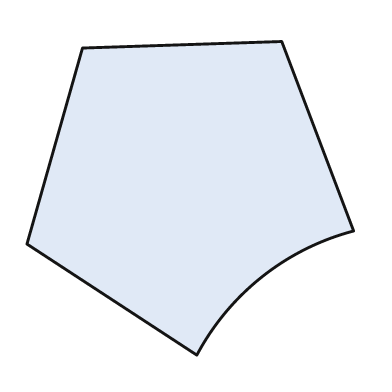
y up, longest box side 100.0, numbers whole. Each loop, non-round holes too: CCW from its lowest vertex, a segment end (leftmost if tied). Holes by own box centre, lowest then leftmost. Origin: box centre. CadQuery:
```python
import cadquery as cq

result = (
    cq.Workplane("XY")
    .moveTo(2.0, -48.0)
    .threePointArc((22.0, -24.0), (50.0, -10.0))
    .lineTo(28.0, 48.0)
    .lineTo(-33.0, 46.0)
    .lineTo(-50.0, -14.0)
    .close()
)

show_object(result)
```